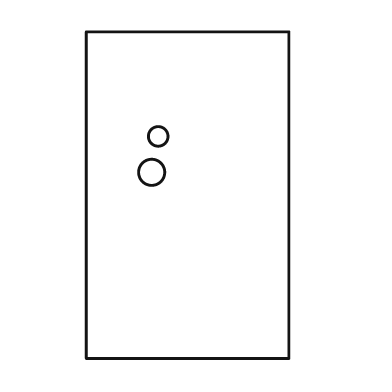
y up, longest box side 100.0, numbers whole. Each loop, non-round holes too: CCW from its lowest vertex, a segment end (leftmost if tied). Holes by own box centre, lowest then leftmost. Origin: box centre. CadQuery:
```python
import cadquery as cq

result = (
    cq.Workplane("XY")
    .moveTo(-31.0, -50.0)
    .lineTo(31.0, -50.0)
    .lineTo(31.0, 50.0)
    .lineTo(-31.0, 50.0)
    .close()
    .moveTo(-11.0, 7.0)
    .circle(4.0)
    .moveTo(-9.0, 18.0)
    .circle(3.0)
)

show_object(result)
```